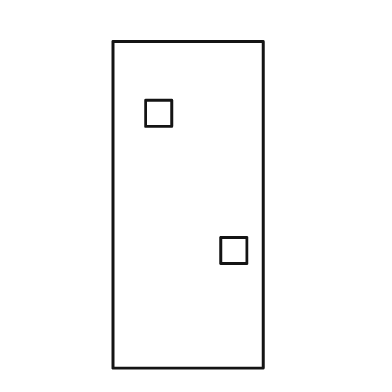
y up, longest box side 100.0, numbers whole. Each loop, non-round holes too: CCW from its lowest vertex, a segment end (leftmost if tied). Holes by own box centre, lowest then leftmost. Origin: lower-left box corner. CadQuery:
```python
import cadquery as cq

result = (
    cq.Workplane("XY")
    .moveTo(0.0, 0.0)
    .lineTo(46.0, 0.0)
    .lineTo(46.0, 100.0)
    .lineTo(0.0, 100.0)
    .close()
    .moveTo(33.0, 32.0)
    .lineTo(41.0, 32.0)
    .lineTo(41.0, 40.0)
    .lineTo(33.0, 40.0)
    .close()
    .moveTo(10.0, 74.0)
    .lineTo(18.0, 74.0)
    .lineTo(18.0, 82.0)
    .lineTo(10.0, 82.0)
    .close()
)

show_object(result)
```